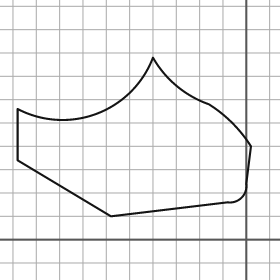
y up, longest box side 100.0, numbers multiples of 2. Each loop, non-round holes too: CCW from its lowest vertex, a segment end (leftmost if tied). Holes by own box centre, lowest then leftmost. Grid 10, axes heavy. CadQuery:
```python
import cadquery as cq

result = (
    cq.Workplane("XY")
    .moveTo(-58.0, 10.0)
    .lineTo(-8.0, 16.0)
    .threePointArc((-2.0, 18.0), (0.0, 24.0))
    .lineTo(2.0, 40.0)
    .threePointArc((-6.0, 50.0), (-16.0, 58.0))
    .threePointArc((-30.0, 66.0), (-40.0, 78.0))
    .threePointArc((-64.0, 54.0), (-98.0, 56.0))
    .lineTo(-98.0, 34.0)
    .close()
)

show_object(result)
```